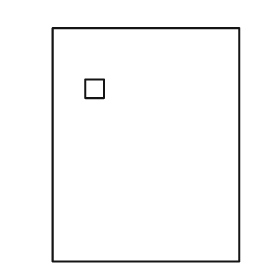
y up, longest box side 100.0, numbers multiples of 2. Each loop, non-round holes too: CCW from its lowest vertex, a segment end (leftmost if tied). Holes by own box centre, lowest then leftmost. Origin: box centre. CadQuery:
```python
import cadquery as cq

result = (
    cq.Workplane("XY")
    .moveTo(-40.0, -50.0)
    .lineTo(40.0, -50.0)
    .lineTo(40.0, 50.0)
    .lineTo(-40.0, 50.0)
    .close()
    .moveTo(-26.0, 20.0)
    .lineTo(-18.0, 20.0)
    .lineTo(-18.0, 28.0)
    .lineTo(-26.0, 28.0)
    .close()
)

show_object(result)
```